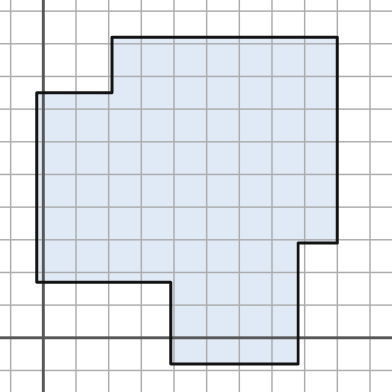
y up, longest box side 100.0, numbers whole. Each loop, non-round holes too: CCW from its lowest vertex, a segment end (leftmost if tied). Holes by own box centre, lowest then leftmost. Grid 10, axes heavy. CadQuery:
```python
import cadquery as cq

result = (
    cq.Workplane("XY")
    .moveTo(39.0, -8.0)
    .lineTo(78.0, -8.0)
    .lineTo(78.0, 29.0)
    .lineTo(90.0, 29.0)
    .lineTo(90.0, 92.0)
    .lineTo(21.0, 92.0)
    .lineTo(21.0, 75.0)
    .lineTo(-2.0, 75.0)
    .lineTo(-2.0, 17.0)
    .lineTo(39.0, 17.0)
    .close()
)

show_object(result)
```